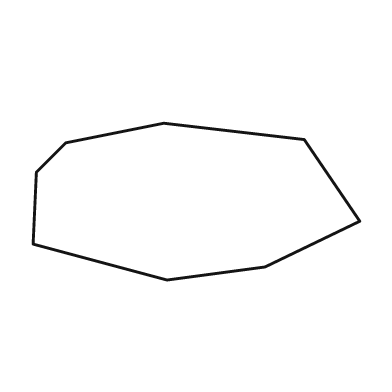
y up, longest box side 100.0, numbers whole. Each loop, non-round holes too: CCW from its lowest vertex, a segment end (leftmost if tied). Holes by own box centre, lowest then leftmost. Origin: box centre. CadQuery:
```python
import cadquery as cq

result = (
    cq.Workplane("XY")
    .moveTo(-9.0, -24.0)
    .lineTo(21.0, -20.0)
    .lineTo(50.0, -6.0)
    .lineTo(33.0, 19.0)
    .lineTo(-10.0, 24.0)
    .lineTo(-40.0, 18.0)
    .lineTo(-49.0, 9.0)
    .lineTo(-50.0, -13.0)
    .close()
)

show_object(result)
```